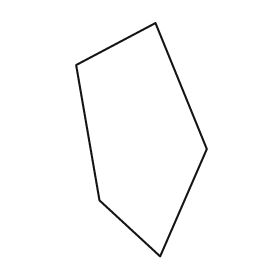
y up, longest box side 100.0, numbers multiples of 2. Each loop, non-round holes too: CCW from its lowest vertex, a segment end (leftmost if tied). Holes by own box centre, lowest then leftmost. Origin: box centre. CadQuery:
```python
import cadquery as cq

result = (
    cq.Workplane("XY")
    .moveTo(8.0, -50.0)
    .lineTo(28.0, -4.0)
    .lineTo(6.0, 50.0)
    .lineTo(-28.0, 32.0)
    .lineTo(-18.0, -26.0)
    .close()
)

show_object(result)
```